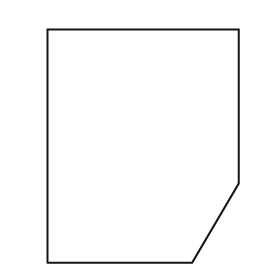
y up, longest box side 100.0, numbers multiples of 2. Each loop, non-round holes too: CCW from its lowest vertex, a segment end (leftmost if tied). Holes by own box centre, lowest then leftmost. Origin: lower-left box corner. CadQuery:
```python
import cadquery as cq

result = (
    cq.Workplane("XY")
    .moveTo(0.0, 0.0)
    .lineTo(62.0, 0.0)
    .lineTo(82.0, 34.0)
    .lineTo(82.0, 100.0)
    .lineTo(0.0, 100.0)
    .close()
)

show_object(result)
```